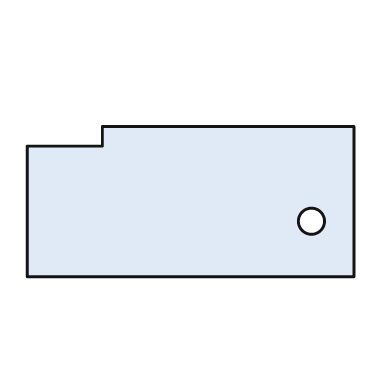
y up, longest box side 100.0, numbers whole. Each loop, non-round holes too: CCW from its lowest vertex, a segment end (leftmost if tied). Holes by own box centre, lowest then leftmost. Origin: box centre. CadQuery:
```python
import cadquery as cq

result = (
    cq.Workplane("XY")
    .moveTo(-50.0, -23.0)
    .lineTo(50.0, -23.0)
    .lineTo(50.0, 23.0)
    .lineTo(-27.0, 23.0)
    .lineTo(-27.0, 17.0)
    .lineTo(-50.0, 17.0)
    .close()
    .moveTo(37.0, -6.0)
    .circle(4.0)
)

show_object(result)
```